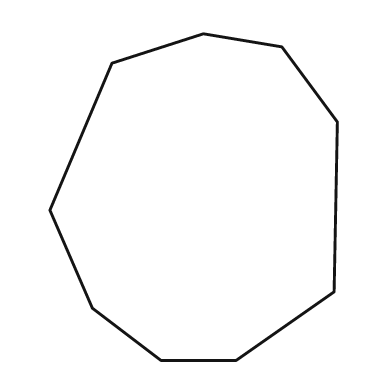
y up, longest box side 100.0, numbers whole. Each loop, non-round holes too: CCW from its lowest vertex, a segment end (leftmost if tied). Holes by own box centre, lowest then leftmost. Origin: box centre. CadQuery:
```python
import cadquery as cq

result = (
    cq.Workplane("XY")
    .moveTo(-10.0, -50.0)
    .lineTo(13.0, -50.0)
    .lineTo(43.0, -29.0)
    .lineTo(44.0, 23.0)
    .lineTo(27.0, 46.0)
    .lineTo(3.0, 50.0)
    .lineTo(-25.0, 41.0)
    .lineTo(-44.0, -4.0)
    .lineTo(-31.0, -34.0)
    .close()
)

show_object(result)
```